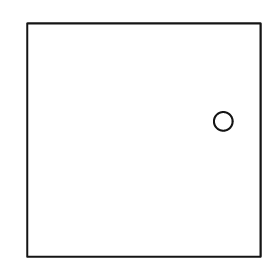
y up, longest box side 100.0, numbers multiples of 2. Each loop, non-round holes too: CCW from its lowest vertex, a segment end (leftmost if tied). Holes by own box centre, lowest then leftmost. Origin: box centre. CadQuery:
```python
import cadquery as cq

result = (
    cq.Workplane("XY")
    .moveTo(-50.0, -50.0)
    .lineTo(50.0, -50.0)
    .lineTo(50.0, 50.0)
    .lineTo(-50.0, 50.0)
    .close()
    .moveTo(34.0, 8.0)
    .circle(4.0)
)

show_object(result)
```